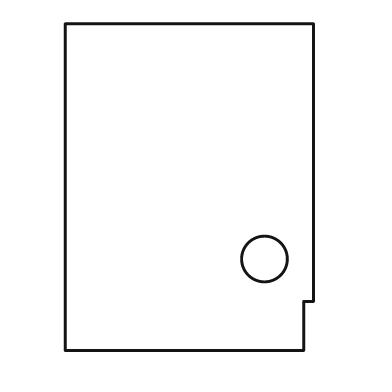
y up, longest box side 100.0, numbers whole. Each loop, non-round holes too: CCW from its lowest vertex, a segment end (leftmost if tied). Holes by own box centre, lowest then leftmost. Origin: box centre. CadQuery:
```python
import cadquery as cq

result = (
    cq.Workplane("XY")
    .moveTo(-38.0, -50.0)
    .lineTo(35.0, -50.0)
    .lineTo(35.0, -35.0)
    .lineTo(38.0, -35.0)
    .lineTo(38.0, 50.0)
    .lineTo(-38.0, 50.0)
    .close()
    .moveTo(23.0, -22.0)
    .circle(7.0)
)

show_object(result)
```